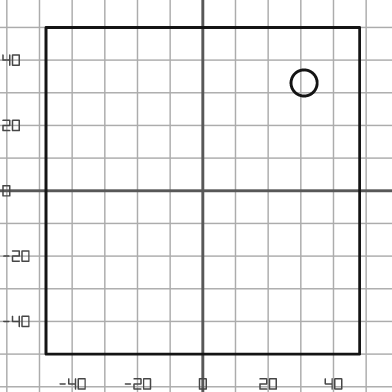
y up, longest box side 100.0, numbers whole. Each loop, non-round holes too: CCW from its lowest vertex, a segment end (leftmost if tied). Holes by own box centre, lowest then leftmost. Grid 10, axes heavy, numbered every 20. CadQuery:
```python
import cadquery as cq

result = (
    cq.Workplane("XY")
    .moveTo(-48.0, -50.0)
    .lineTo(48.0, -50.0)
    .lineTo(48.0, 50.0)
    .lineTo(-48.0, 50.0)
    .close()
    .moveTo(31.0, 33.0)
    .circle(4.0)
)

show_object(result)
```